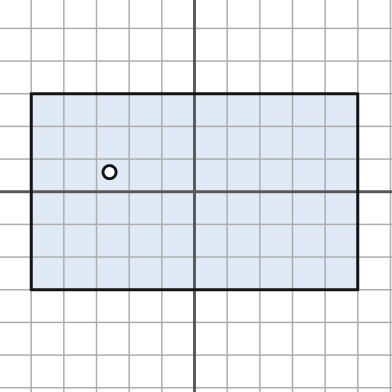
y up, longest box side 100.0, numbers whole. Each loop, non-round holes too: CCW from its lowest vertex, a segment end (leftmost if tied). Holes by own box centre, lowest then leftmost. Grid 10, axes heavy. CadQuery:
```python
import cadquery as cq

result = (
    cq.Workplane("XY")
    .moveTo(-50.0, -30.0)
    .lineTo(50.0, -30.0)
    .lineTo(50.0, 30.0)
    .lineTo(-50.0, 30.0)
    .close()
    .moveTo(-26.0, 6.0)
    .circle(2.0)
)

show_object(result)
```